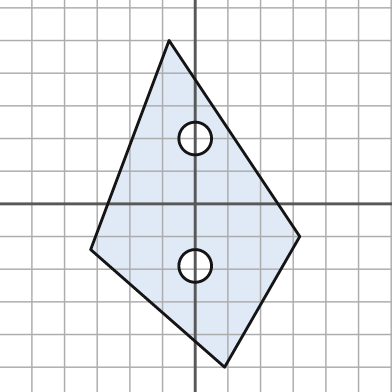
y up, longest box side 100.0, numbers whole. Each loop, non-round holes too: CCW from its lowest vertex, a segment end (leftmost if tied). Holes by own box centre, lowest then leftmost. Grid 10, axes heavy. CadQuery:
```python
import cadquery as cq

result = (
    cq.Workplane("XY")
    .moveTo(9.0, -50.0)
    .lineTo(32.0, -10.0)
    .lineTo(-8.0, 50.0)
    .lineTo(-32.0, -14.0)
    .close()
    .moveTo(0.0, -19.0)
    .circle(5.0)
    .moveTo(0.0, 20.0)
    .circle(5.0)
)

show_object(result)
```